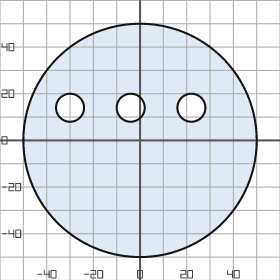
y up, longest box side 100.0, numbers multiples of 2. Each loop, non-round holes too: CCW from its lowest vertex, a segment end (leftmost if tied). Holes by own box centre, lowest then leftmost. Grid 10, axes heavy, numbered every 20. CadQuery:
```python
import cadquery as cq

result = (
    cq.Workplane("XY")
    .moveTo(0.0, 0.0)
    .circle(50.0)
    .moveTo(-30.0, 14.0)
    .circle(6.0)
    .moveTo(-4.0, 14.0)
    .circle(6.0)
    .moveTo(22.0, 14.0)
    .circle(6.0)
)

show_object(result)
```